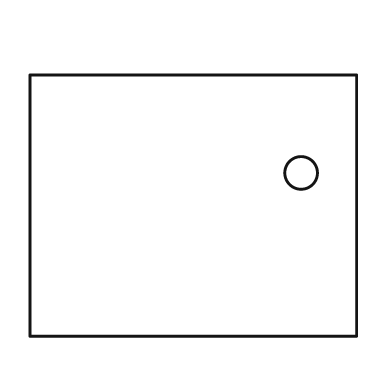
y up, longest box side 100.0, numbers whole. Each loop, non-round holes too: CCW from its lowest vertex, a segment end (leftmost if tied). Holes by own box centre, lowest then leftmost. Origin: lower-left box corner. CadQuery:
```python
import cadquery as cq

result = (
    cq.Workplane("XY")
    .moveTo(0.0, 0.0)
    .lineTo(100.0, 0.0)
    .lineTo(100.0, 80.0)
    .lineTo(0.0, 80.0)
    .close()
    .moveTo(83.0, 50.0)
    .circle(5.0)
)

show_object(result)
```